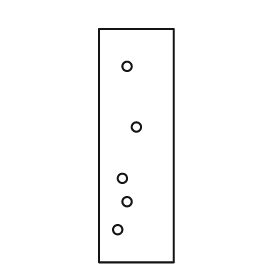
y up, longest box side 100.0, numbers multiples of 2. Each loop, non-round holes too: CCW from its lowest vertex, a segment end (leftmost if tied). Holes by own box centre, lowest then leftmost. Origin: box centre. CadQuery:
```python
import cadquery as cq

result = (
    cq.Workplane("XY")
    .moveTo(-16.0, -50.0)
    .lineTo(16.0, -50.0)
    .lineTo(16.0, 50.0)
    .lineTo(-16.0, 50.0)
    .close()
    .moveTo(-8.0, -36.0)
    .circle(2.0)
    .moveTo(-4.0, -24.0)
    .circle(2.0)
    .moveTo(-6.0, -14.0)
    .circle(2.0)
    .moveTo(0.0, 8.0)
    .circle(2.0)
    .moveTo(-4.0, 34.0)
    .circle(2.0)
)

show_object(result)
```